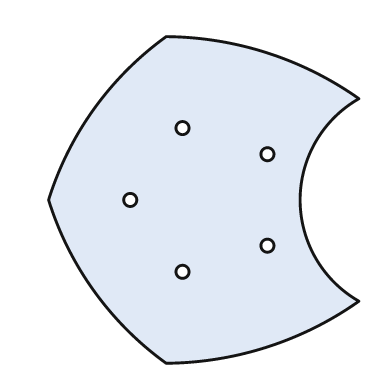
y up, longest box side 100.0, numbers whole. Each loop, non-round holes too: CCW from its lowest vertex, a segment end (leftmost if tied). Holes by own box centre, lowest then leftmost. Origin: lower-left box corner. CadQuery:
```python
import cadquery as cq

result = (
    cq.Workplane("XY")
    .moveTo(36.0, 0.0)
    .threePointArc((67.0, 5.0), (95.0, 19.0))
    .threePointArc((77.0, 50.0), (95.0, 81.0))
    .threePointArc((67.0, 95.0), (36.0, 100.0))
    .threePointArc((14.0, 78.0), (0.0, 50.0))
    .threePointArc((14.0, 22.0), (36.0, 0.0))
    .close()
    .moveTo(41.0, 28.0)
    .circle(2.0)
    .moveTo(67.0, 36.0)
    .circle(2.0)
    .moveTo(25.0, 50.0)
    .circle(2.0)
    .moveTo(67.0, 64.0)
    .circle(2.0)
    .moveTo(41.0, 72.0)
    .circle(2.0)
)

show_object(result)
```